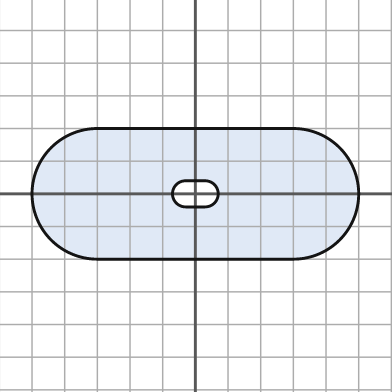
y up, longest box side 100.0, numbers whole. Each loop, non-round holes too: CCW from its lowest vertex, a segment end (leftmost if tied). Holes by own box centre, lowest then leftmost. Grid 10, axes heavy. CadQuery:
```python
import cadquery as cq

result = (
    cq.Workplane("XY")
    .moveTo(-30.0, -20.0)
    .lineTo(30.0, -20.0)
    .threePointArc((50.0, 0.0), (30.0, 20.0))
    .lineTo(-30.0, 20.0)
    .threePointArc((-50.0, 0.0), (-30.0, -20.0))
    .close()
    .moveTo(-3.0, -4.0)
    .lineTo(3.0, -4.0)
    .threePointArc((7.0, 0.0), (3.0, 4.0))
    .lineTo(-3.0, 4.0)
    .threePointArc((-7.0, 0.0), (-3.0, -4.0))
    .close()
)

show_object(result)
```